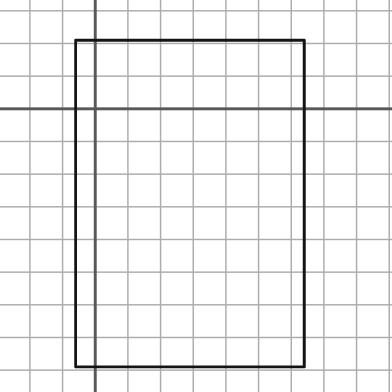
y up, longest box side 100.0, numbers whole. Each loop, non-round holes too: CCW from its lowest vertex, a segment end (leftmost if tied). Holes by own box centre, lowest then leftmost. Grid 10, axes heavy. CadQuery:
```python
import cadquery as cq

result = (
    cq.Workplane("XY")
    .moveTo(-6.0, -79.0)
    .lineTo(64.0, -79.0)
    .lineTo(64.0, 21.0)
    .lineTo(-6.0, 21.0)
    .close()
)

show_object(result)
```